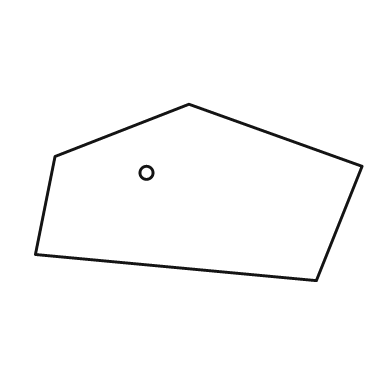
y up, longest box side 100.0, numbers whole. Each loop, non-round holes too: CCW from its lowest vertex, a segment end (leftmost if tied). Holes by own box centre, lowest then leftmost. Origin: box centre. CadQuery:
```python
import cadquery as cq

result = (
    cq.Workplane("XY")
    .moveTo(36.0, -27.0)
    .lineTo(50.0, 8.0)
    .lineTo(-3.0, 27.0)
    .lineTo(-44.0, 11.0)
    .lineTo(-50.0, -19.0)
    .close()
    .moveTo(-16.0, 6.0)
    .circle(2.0)
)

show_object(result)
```